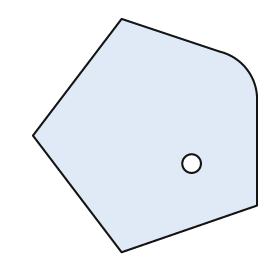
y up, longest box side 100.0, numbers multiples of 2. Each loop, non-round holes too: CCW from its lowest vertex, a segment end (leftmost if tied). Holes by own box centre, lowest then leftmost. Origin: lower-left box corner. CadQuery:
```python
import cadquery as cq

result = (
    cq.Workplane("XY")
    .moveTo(38.0, 0.0)
    .lineTo(96.0, 20.0)
    .lineTo(96.0, 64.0)
    .threePointArc((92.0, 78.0), (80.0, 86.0))
    .lineTo(38.0, 100.0)
    .lineTo(0.0, 50.0)
    .close()
    .moveTo(68.0, 38.0)
    .circle(4.0)
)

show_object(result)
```